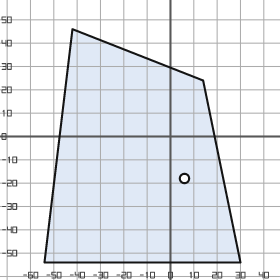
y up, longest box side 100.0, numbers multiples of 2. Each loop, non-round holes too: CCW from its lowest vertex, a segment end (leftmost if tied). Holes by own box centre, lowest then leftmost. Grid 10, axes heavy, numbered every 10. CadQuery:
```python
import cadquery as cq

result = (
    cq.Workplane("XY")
    .moveTo(-54.0, -54.0)
    .lineTo(30.0, -54.0)
    .lineTo(14.0, 24.0)
    .lineTo(-42.0, 46.0)
    .close()
    .moveTo(6.0, -18.0)
    .circle(2.0)
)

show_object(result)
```